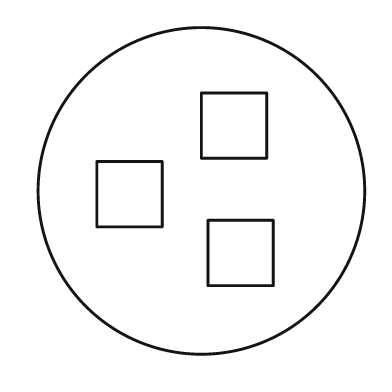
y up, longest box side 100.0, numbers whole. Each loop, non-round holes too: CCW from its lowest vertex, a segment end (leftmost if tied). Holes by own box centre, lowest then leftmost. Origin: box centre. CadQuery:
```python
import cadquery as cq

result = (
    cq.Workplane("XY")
    .moveTo(0.0, 0.0)
    .circle(50.0)
    .moveTo(2.0, -29.0)
    .lineTo(22.0, -29.0)
    .lineTo(22.0, -9.0)
    .lineTo(2.0, -9.0)
    .close()
    .moveTo(-32.0, -11.0)
    .lineTo(-12.0, -11.0)
    .lineTo(-12.0, 9.0)
    .lineTo(-32.0, 9.0)
    .close()
    .moveTo(0.0, 10.0)
    .lineTo(20.0, 10.0)
    .lineTo(20.0, 30.0)
    .lineTo(0.0, 30.0)
    .close()
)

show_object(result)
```